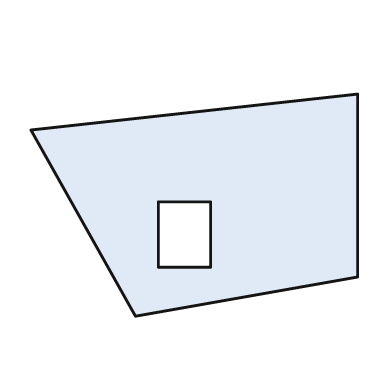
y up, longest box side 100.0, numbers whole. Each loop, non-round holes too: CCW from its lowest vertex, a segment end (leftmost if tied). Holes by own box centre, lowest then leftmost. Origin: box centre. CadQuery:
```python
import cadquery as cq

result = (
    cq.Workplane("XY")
    .moveTo(-18.0, -34.0)
    .lineTo(50.0, -22.0)
    .lineTo(50.0, 34.0)
    .lineTo(-50.0, 23.0)
    .close()
    .moveTo(-11.0, -19.0)
    .lineTo(5.0, -19.0)
    .lineTo(5.0, 1.0)
    .lineTo(-11.0, 1.0)
    .close()
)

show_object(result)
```